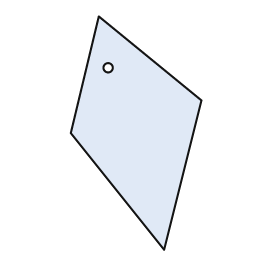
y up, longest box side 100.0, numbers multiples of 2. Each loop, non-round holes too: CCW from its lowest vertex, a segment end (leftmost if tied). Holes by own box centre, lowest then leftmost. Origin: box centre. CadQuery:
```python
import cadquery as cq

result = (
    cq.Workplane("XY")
    .moveTo(12.0, -50.0)
    .lineTo(28.0, 14.0)
    .lineTo(-16.0, 50.0)
    .lineTo(-28.0, 0.0)
    .close()
    .moveTo(-12.0, 28.0)
    .circle(2.0)
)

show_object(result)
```